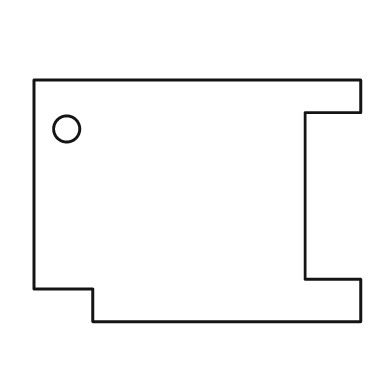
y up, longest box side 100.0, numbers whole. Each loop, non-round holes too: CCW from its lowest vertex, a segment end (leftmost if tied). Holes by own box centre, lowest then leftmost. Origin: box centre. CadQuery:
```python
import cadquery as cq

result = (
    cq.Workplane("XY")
    .moveTo(-32.0, -37.0)
    .lineTo(50.0, -37.0)
    .lineTo(50.0, -24.0)
    .lineTo(33.0, -24.0)
    .lineTo(33.0, 27.0)
    .lineTo(50.0, 27.0)
    .lineTo(50.0, 37.0)
    .lineTo(-50.0, 37.0)
    .lineTo(-50.0, -27.0)
    .lineTo(-32.0, -27.0)
    .close()
    .moveTo(-40.0, 22.0)
    .circle(4.0)
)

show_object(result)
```